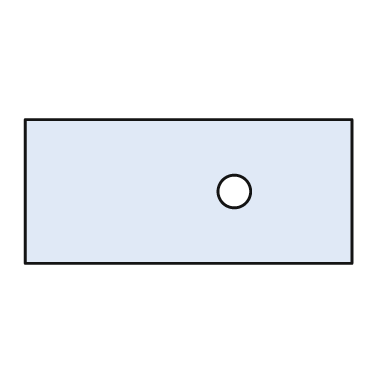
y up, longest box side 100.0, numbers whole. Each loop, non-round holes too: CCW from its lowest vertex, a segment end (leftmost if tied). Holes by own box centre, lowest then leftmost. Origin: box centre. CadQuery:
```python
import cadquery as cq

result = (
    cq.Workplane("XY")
    .moveTo(-50.0, -22.0)
    .lineTo(50.0, -22.0)
    .lineTo(50.0, 22.0)
    .lineTo(-50.0, 22.0)
    .close()
    .moveTo(14.0, 0.0)
    .circle(5.0)
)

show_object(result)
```